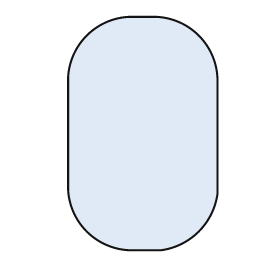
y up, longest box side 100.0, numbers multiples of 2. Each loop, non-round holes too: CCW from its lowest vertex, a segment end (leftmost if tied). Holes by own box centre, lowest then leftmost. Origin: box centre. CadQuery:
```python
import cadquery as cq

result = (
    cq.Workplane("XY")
    .moveTo(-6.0, -50.0)
    .lineTo(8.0, -50.0)
    .threePointArc((24.0, -42.0), (32.0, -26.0))
    .lineTo(32.0, 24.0)
    .threePointArc((24.0, 42.0), (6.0, 50.0))
    .lineTo(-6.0, 50.0)
    .threePointArc((-24.0, 42.0), (-32.0, 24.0))
    .lineTo(-32.0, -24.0)
    .threePointArc((-24.0, -42.0), (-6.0, -50.0))
    .close()
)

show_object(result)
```